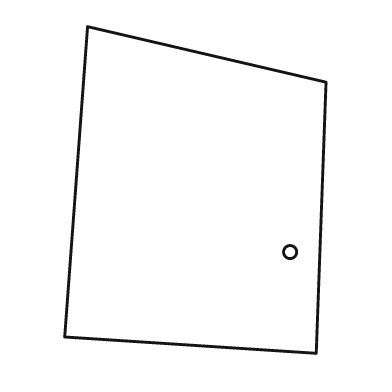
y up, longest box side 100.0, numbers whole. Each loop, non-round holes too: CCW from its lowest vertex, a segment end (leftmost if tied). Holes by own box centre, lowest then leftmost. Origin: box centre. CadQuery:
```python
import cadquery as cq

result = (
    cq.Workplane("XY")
    .moveTo(37.0, -50.0)
    .lineTo(40.0, 33.0)
    .lineTo(-33.0, 50.0)
    .lineTo(-40.0, -45.0)
    .close()
    .moveTo(29.0, -19.0)
    .circle(2.0)
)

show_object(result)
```